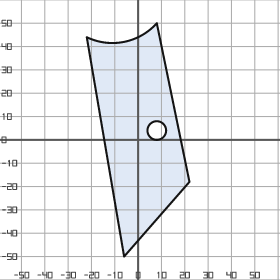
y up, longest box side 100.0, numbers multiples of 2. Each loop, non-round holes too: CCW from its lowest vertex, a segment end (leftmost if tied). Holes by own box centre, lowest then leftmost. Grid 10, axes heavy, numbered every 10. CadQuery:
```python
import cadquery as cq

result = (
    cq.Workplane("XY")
    .moveTo(-6.0, -50.0)
    .lineTo(22.0, -18.0)
    .lineTo(8.0, 50.0)
    .threePointArc((-6.0, 42.0), (-22.0, 44.0))
    .close()
    .moveTo(8.0, 4.0)
    .circle(4.0)
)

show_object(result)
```